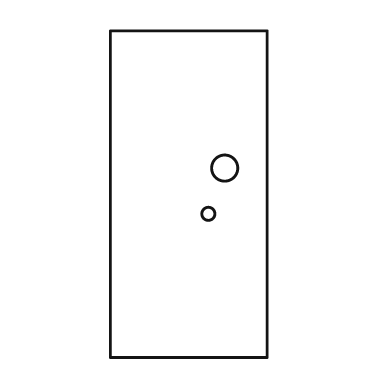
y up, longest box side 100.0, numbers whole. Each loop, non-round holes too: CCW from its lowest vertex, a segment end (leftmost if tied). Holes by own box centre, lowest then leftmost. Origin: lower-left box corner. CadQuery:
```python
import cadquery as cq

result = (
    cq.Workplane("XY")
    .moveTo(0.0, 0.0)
    .lineTo(48.0, 0.0)
    .lineTo(48.0, 100.0)
    .lineTo(0.0, 100.0)
    .close()
    .moveTo(30.0, 44.0)
    .circle(2.0)
    .moveTo(35.0, 58.0)
    .circle(4.0)
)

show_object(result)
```